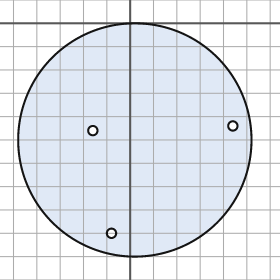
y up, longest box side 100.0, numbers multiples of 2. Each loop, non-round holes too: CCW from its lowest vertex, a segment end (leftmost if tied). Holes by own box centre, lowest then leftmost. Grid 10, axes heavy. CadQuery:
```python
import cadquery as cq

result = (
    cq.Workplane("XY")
    .moveTo(2.0, -50.0)
    .circle(50.0)
    .moveTo(-8.0, -90.0)
    .circle(2.0)
    .moveTo(-16.0, -46.0)
    .circle(2.0)
    .moveTo(44.0, -44.0)
    .circle(2.0)
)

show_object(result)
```